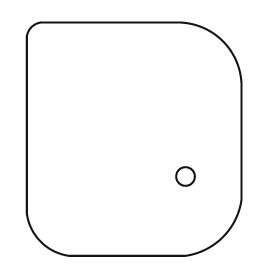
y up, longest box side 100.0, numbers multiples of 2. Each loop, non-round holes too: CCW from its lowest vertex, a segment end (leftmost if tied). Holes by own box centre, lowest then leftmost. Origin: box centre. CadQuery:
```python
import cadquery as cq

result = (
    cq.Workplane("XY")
    .moveTo(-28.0, -50.0)
    .lineTo(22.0, -50.0)
    .threePointArc((38.0, -42.0), (46.0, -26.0))
    .lineTo(46.0, 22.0)
    .threePointArc((38.0, 42.0), (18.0, 50.0))
    .lineTo(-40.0, 50.0)
    .threePointArc((-44.0, 48.0), (-46.0, 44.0))
    .lineTo(-46.0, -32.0)
    .threePointArc((-40.0, -44.0), (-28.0, -50.0))
    .close()
    .moveTo(22.0, -16.0)
    .circle(4.0)
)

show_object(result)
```